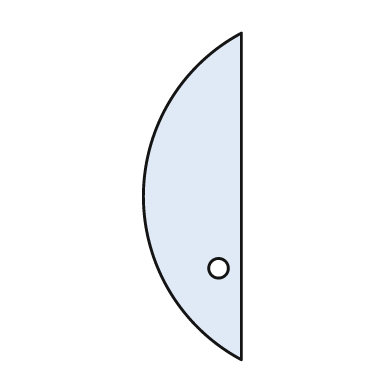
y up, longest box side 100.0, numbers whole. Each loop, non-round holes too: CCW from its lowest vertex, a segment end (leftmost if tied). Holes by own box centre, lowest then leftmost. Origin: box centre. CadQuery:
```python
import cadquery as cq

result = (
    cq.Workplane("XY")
    .moveTo(15.0, -50.0)
    .lineTo(15.0, 50.0)
    .threePointArc((-15.0, 0.0), (15.0, -50.0))
    .close()
    .moveTo(8.0, -22.0)
    .circle(3.0)
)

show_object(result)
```